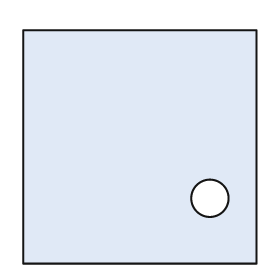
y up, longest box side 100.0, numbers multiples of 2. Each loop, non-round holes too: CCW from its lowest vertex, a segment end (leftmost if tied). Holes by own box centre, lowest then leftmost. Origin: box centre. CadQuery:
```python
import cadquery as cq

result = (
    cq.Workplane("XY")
    .moveTo(-50.0, -50.0)
    .lineTo(50.0, -50.0)
    .lineTo(50.0, 50.0)
    .lineTo(-50.0, 50.0)
    .close()
    .moveTo(30.0, -22.0)
    .circle(8.0)
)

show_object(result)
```